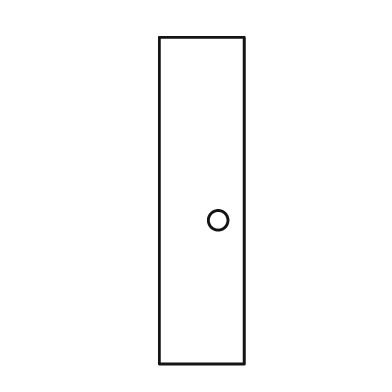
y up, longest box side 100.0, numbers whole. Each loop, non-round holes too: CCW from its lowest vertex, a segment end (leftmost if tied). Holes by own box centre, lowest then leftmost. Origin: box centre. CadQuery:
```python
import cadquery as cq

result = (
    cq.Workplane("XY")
    .moveTo(-13.0, -50.0)
    .lineTo(13.0, -50.0)
    .lineTo(13.0, 50.0)
    .lineTo(-13.0, 50.0)
    .close()
    .moveTo(5.0, -6.0)
    .circle(3.0)
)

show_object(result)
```